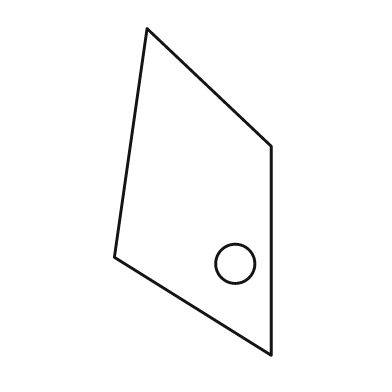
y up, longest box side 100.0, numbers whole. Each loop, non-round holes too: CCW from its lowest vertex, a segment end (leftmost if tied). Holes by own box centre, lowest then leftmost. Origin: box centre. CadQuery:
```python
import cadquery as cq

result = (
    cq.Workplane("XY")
    .moveTo(24.0, -50.0)
    .lineTo(24.0, 14.0)
    .lineTo(-14.0, 50.0)
    .lineTo(-24.0, -20.0)
    .close()
    .moveTo(13.0, -22.0)
    .circle(6.0)
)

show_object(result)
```